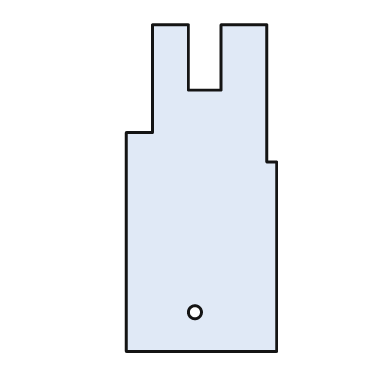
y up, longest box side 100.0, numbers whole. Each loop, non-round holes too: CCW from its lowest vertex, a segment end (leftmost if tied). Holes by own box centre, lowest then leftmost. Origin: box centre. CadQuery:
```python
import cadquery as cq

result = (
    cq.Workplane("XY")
    .moveTo(-23.0, -50.0)
    .lineTo(23.0, -50.0)
    .lineTo(23.0, 8.0)
    .lineTo(20.0, 8.0)
    .lineTo(20.0, 50.0)
    .lineTo(6.0, 50.0)
    .lineTo(6.0, 30.0)
    .lineTo(-4.0, 30.0)
    .lineTo(-4.0, 50.0)
    .lineTo(-15.0, 50.0)
    .lineTo(-15.0, 17.0)
    .lineTo(-23.0, 17.0)
    .close()
    .moveTo(-2.0, -38.0)
    .circle(2.0)
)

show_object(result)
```